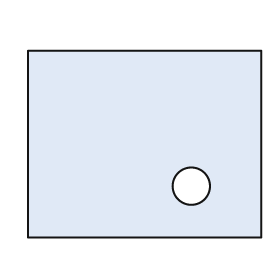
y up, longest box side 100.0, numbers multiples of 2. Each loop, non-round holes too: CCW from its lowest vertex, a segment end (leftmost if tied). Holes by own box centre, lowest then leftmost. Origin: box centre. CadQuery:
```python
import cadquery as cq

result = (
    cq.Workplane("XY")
    .moveTo(-50.0, -40.0)
    .lineTo(50.0, -40.0)
    .lineTo(50.0, 40.0)
    .lineTo(-50.0, 40.0)
    .close()
    .moveTo(20.0, -18.0)
    .circle(8.0)
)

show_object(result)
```